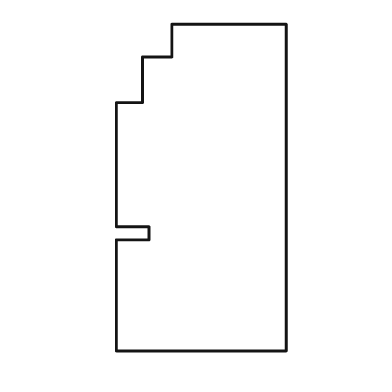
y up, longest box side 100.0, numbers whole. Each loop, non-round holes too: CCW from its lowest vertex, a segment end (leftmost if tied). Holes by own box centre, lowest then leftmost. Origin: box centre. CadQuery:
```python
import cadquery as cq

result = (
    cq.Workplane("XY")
    .moveTo(-26.0, -50.0)
    .lineTo(26.0, -50.0)
    .lineTo(26.0, 50.0)
    .lineTo(-9.0, 50.0)
    .lineTo(-9.0, 40.0)
    .lineTo(-18.0, 40.0)
    .lineTo(-18.0, 26.0)
    .lineTo(-26.0, 26.0)
    .lineTo(-26.0, -12.0)
    .lineTo(-16.0, -12.0)
    .lineTo(-16.0, -16.0)
    .lineTo(-26.0, -16.0)
    .close()
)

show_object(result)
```